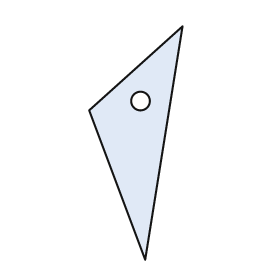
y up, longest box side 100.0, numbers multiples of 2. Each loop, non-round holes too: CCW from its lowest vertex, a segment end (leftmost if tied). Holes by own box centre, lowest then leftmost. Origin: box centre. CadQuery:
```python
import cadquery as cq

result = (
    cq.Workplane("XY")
    .moveTo(4.0, -50.0)
    .lineTo(20.0, 50.0)
    .lineTo(-20.0, 14.0)
    .close()
    .moveTo(2.0, 18.0)
    .circle(4.0)
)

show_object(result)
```